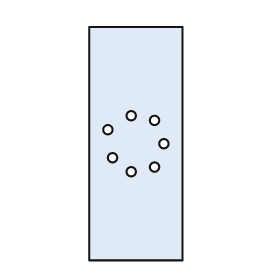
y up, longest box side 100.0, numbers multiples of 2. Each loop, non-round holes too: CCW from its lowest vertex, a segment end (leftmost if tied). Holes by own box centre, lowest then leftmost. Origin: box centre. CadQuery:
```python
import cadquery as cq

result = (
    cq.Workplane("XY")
    .moveTo(-20.0, -50.0)
    .lineTo(20.0, -50.0)
    .lineTo(20.0, 50.0)
    .lineTo(-20.0, 50.0)
    .close()
    .moveTo(-2.0, -12.0)
    .circle(2.0)
    .moveTo(8.0, -10.0)
    .circle(2.0)
    .moveTo(-10.0, -6.0)
    .circle(2.0)
    .moveTo(12.0, 0.0)
    .circle(2.0)
    .moveTo(-12.0, 6.0)
    .circle(2.0)
    .moveTo(8.0, 10.0)
    .circle(2.0)
    .moveTo(-2.0, 12.0)
    .circle(2.0)
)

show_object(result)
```